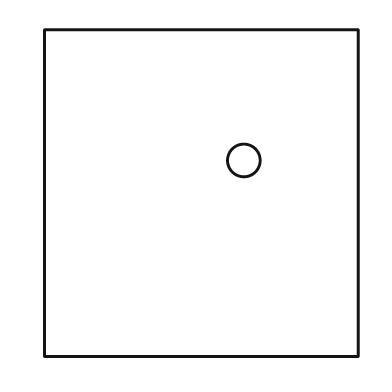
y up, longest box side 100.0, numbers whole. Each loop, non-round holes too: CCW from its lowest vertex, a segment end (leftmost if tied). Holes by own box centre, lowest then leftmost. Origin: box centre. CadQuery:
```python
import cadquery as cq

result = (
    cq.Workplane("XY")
    .moveTo(-48.0, -50.0)
    .lineTo(48.0, -50.0)
    .lineTo(48.0, 50.0)
    .lineTo(-48.0, 50.0)
    .close()
    .moveTo(13.0, 10.0)
    .circle(5.0)
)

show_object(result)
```